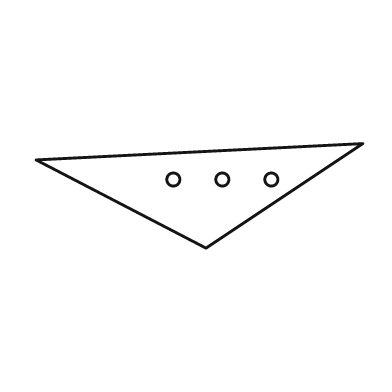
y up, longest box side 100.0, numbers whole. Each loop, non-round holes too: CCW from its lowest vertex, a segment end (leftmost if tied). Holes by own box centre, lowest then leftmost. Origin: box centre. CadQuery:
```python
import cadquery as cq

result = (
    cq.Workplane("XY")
    .moveTo(2.0, -16.0)
    .lineTo(50.0, 16.0)
    .lineTo(-50.0, 11.0)
    .close()
    .moveTo(-8.0, 5.0)
    .circle(2.0)
    .moveTo(7.0, 5.0)
    .circle(2.0)
    .moveTo(22.0, 5.0)
    .circle(2.0)
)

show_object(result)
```